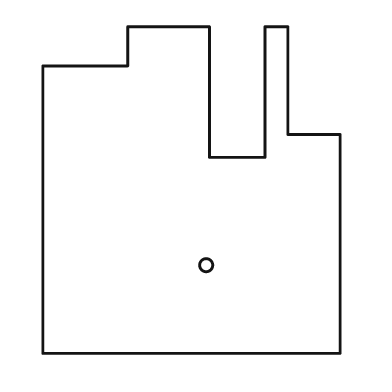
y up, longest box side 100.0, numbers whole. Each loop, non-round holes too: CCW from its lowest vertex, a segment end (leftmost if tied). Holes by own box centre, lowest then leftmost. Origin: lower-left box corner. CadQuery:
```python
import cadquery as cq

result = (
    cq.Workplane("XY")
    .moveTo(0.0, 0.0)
    .lineTo(91.0, 0.0)
    .lineTo(91.0, 67.0)
    .lineTo(75.0, 67.0)
    .lineTo(75.0, 100.0)
    .lineTo(68.0, 100.0)
    .lineTo(68.0, 60.0)
    .lineTo(51.0, 60.0)
    .lineTo(51.0, 100.0)
    .lineTo(26.0, 100.0)
    .lineTo(26.0, 88.0)
    .lineTo(0.0, 88.0)
    .close()
    .moveTo(50.0, 27.0)
    .circle(2.0)
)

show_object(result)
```